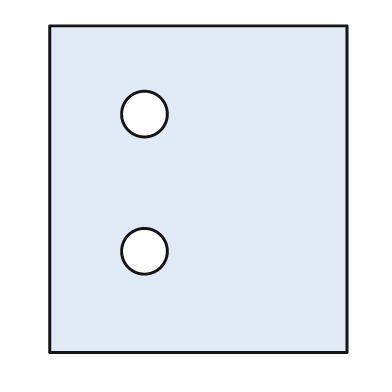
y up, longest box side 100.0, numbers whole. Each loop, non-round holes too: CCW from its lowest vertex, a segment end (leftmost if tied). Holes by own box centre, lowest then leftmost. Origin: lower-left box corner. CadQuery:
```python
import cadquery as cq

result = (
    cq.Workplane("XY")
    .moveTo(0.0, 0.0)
    .lineTo(91.0, 0.0)
    .lineTo(91.0, 100.0)
    .lineTo(0.0, 100.0)
    .close()
    .moveTo(29.0, 31.0)
    .circle(7.0)
    .moveTo(29.0, 73.0)
    .circle(7.0)
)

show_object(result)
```